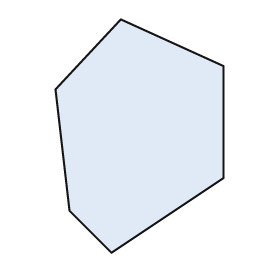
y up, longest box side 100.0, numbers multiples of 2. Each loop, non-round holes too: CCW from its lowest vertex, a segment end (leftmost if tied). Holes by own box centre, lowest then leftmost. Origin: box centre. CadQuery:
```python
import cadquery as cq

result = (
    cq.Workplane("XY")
    .moveTo(-12.0, -50.0)
    .lineTo(36.0, -18.0)
    .lineTo(36.0, 30.0)
    .lineTo(-8.0, 50.0)
    .lineTo(-36.0, 20.0)
    .lineTo(-30.0, -32.0)
    .close()
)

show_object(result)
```